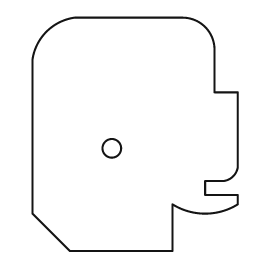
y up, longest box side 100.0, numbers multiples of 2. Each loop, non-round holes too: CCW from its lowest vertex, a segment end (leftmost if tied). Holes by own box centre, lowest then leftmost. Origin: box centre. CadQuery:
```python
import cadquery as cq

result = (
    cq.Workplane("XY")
    .moveTo(-28.0, -50.0)
    .lineTo(16.0, -50.0)
    .lineTo(16.0, -30.0)
    .threePointArc((30.0, -34.0), (44.0, -30.0))
    .lineTo(44.0, -26.0)
    .lineTo(30.0, -26.0)
    .lineTo(30.0, -20.0)
    .lineTo(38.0, -20.0)
    .threePointArc((42.0, -18.0), (44.0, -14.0))
    .lineTo(44.0, 18.0)
    .lineTo(34.0, 18.0)
    .lineTo(34.0, 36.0)
    .threePointArc((30.0, 46.0), (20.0, 50.0))
    .lineTo(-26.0, 50.0)
    .threePointArc((-38.0, 44.0), (-44.0, 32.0))
    .lineTo(-44.0, -34.0)
    .close()
    .moveTo(-10.0, -6.0)
    .circle(4.0)
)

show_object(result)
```